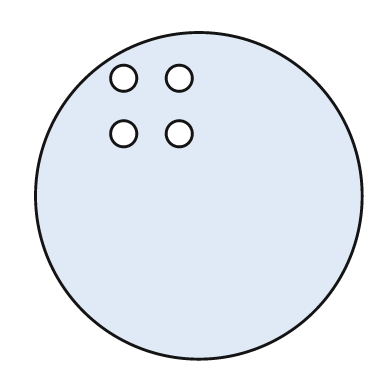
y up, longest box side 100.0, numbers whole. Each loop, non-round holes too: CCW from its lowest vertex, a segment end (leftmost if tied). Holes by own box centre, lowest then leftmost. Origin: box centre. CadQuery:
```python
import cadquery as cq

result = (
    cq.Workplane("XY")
    .moveTo(0.0, 0.0)
    .circle(50.0)
    .moveTo(-23.0, 19.0)
    .circle(4.0)
    .moveTo(-6.0, 19.0)
    .circle(4.0)
    .moveTo(-23.0, 36.0)
    .circle(4.0)
    .moveTo(-6.0, 36.0)
    .circle(4.0)
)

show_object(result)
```